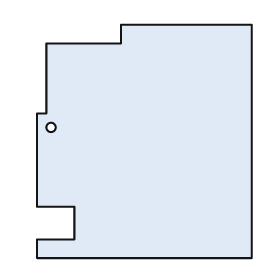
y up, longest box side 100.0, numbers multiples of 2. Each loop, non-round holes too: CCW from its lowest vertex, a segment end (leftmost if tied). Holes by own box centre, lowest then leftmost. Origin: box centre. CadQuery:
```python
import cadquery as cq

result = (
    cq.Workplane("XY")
    .moveTo(-46.0, -50.0)
    .lineTo(46.0, -50.0)
    .lineTo(46.0, 50.0)
    .lineTo(-10.0, 50.0)
    .lineTo(-10.0, 42.0)
    .lineTo(-42.0, 42.0)
    .lineTo(-42.0, 12.0)
    .lineTo(-46.0, 12.0)
    .lineTo(-46.0, -28.0)
    .lineTo(-30.0, -28.0)
    .lineTo(-30.0, -42.0)
    .lineTo(-46.0, -42.0)
    .close()
    .moveTo(-40.0, 6.0)
    .circle(2.0)
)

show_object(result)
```